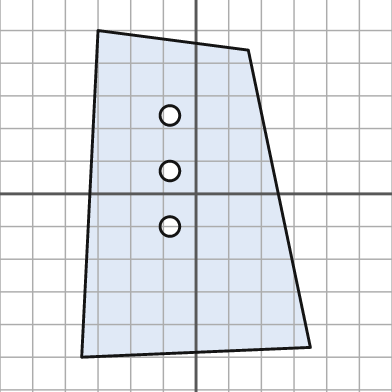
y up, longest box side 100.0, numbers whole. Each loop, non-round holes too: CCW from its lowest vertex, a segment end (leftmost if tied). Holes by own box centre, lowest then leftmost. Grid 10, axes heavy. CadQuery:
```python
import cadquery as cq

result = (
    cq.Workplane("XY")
    .moveTo(-35.0, -50.0)
    .lineTo(35.0, -47.0)
    .lineTo(16.0, 44.0)
    .lineTo(-30.0, 50.0)
    .close()
    .moveTo(-8.0, -10.0)
    .circle(3.0)
    .moveTo(-8.0, 7.0)
    .circle(3.0)
    .moveTo(-8.0, 24.0)
    .circle(3.0)
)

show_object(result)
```